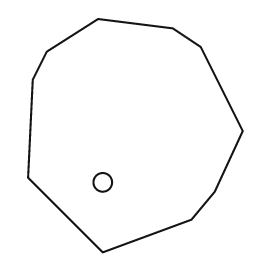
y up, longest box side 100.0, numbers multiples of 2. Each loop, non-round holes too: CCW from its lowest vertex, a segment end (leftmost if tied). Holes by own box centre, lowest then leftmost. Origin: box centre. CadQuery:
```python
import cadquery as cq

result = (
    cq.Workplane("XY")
    .moveTo(-14.0, -50.0)
    .lineTo(24.0, -36.0)
    .lineTo(34.0, -24.0)
    .lineTo(46.0, 2.0)
    .lineTo(28.0, 38.0)
    .lineTo(16.0, 46.0)
    .lineTo(-16.0, 50.0)
    .lineTo(-38.0, 36.0)
    .lineTo(-44.0, 24.0)
    .lineTo(-46.0, -18.0)
    .close()
    .moveTo(-14.0, -20.0)
    .circle(4.0)
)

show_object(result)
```